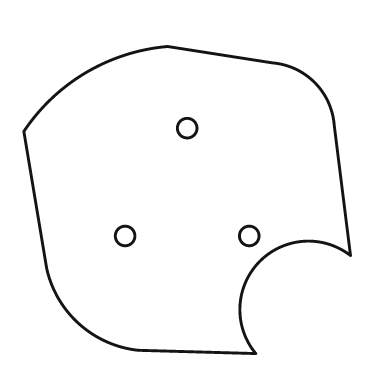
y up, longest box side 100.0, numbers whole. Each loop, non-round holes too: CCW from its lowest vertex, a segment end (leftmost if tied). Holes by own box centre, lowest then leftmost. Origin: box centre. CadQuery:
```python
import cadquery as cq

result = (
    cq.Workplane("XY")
    .moveTo(21.0, -47.0)
    .threePointArc((22.0, -19.0), (50.0, -17.0))
    .lineTo(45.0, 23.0)
    .threePointArc((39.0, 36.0), (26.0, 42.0))
    .lineTo(-6.0, 47.0)
    .threePointArc((-31.0, 39.0), (-50.0, 21.0))
    .lineTo(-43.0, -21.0)
    .threePointArc((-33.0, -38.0), (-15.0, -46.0))
    .close()
    .moveTo(-19.0, -11.0)
    .circle(3.0)
    .moveTo(19.0, -11.0)
    .circle(3.0)
    .moveTo(0.0, 22.0)
    .circle(3.0)
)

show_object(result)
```